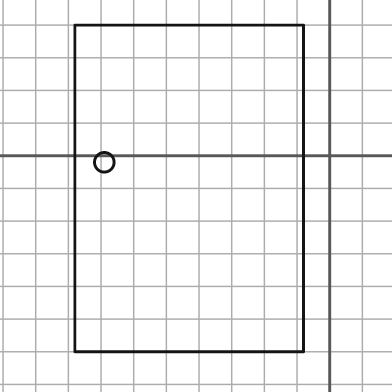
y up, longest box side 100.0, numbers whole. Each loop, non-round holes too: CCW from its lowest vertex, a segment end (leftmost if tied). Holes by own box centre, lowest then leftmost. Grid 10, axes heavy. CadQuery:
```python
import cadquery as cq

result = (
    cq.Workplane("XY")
    .moveTo(-78.0, -60.0)
    .lineTo(-8.0, -60.0)
    .lineTo(-8.0, 40.0)
    .lineTo(-78.0, 40.0)
    .close()
    .moveTo(-69.0, -2.0)
    .circle(3.0)
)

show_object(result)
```